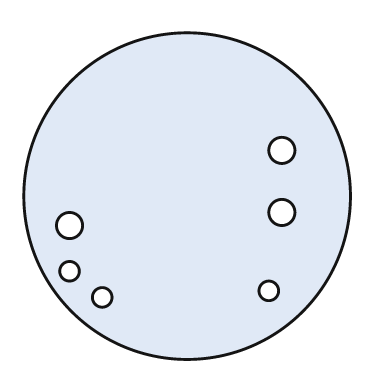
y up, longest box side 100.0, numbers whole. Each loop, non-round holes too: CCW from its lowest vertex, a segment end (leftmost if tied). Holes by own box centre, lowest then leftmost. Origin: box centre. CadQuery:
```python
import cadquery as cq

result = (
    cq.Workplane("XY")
    .moveTo(0.0, 0.0)
    .circle(50.0)
    .moveTo(-26.0, -31.0)
    .circle(3.0)
    .moveTo(25.0, -29.0)
    .circle(3.0)
    .moveTo(-36.0, -23.0)
    .circle(3.0)
    .moveTo(-36.0, -9.0)
    .circle(4.0)
    .moveTo(29.0, -5.0)
    .circle(4.0)
    .moveTo(29.0, 14.0)
    .circle(4.0)
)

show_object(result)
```